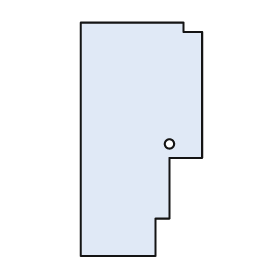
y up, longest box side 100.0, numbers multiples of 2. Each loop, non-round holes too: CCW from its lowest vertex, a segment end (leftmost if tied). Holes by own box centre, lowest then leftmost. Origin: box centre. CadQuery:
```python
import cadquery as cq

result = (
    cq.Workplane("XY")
    .moveTo(-26.0, -50.0)
    .lineTo(6.0, -50.0)
    .lineTo(6.0, -34.0)
    .lineTo(12.0, -34.0)
    .lineTo(12.0, -8.0)
    .lineTo(26.0, -8.0)
    .lineTo(26.0, 46.0)
    .lineTo(18.0, 46.0)
    .lineTo(18.0, 50.0)
    .lineTo(-26.0, 50.0)
    .close()
    .moveTo(12.0, -2.0)
    .circle(2.0)
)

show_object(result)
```